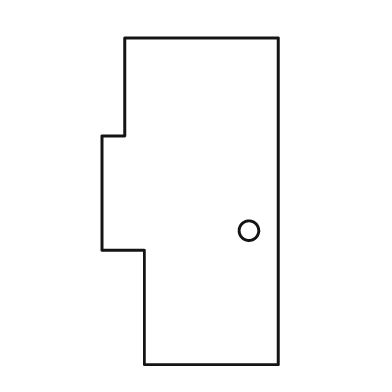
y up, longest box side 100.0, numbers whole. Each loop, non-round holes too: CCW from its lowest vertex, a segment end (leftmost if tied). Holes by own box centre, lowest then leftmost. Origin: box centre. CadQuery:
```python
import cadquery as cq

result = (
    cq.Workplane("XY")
    .moveTo(-14.0, -50.0)
    .lineTo(27.0, -50.0)
    .lineTo(27.0, 50.0)
    .lineTo(-20.0, 50.0)
    .lineTo(-20.0, 20.0)
    .lineTo(-27.0, 20.0)
    .lineTo(-27.0, -15.0)
    .lineTo(-14.0, -15.0)
    .close()
    .moveTo(18.0, -9.0)
    .circle(3.0)
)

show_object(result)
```